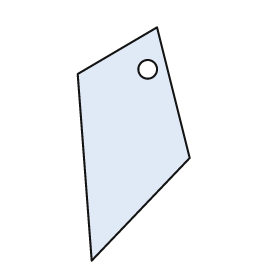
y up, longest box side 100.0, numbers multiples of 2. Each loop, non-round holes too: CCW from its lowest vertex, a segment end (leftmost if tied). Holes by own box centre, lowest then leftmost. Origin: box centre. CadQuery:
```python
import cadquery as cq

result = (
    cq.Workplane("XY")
    .moveTo(-18.0, -50.0)
    .lineTo(24.0, -6.0)
    .lineTo(10.0, 50.0)
    .lineTo(-24.0, 30.0)
    .close()
    .moveTo(6.0, 32.0)
    .circle(4.0)
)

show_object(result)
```